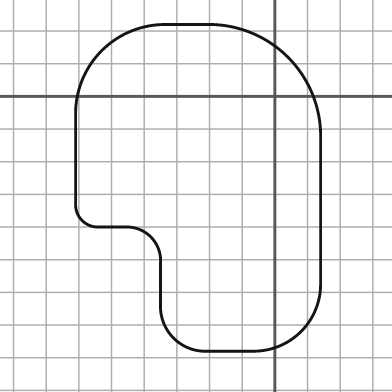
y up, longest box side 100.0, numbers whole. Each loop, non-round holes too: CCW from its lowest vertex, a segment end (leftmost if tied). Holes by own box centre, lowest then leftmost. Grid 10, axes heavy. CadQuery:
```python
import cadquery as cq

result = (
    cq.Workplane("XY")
    .moveTo(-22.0, -78.0)
    .lineTo(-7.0, -78.0)
    .threePointArc((8.0, -72.0), (14.0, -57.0))
    .lineTo(14.0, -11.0)
    .threePointArc((4.0, 12.0), (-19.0, 22.0))
    .lineTo(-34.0, 22.0)
    .threePointArc((-53.0, 14.0), (-61.0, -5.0))
    .lineTo(-61.0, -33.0)
    .threePointArc((-59.0, -38.0), (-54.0, -40.0))
    .lineTo(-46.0, -40.0)
    .threePointArc((-38.0, -43.0), (-35.0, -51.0))
    .lineTo(-35.0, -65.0)
    .threePointArc((-31.0, -74.0), (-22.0, -78.0))
    .close()
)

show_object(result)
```